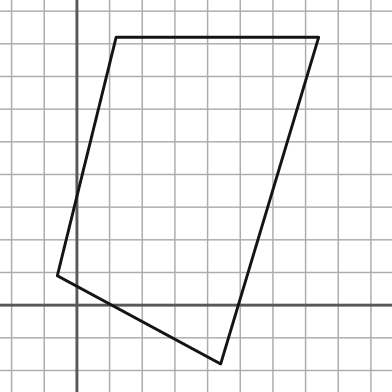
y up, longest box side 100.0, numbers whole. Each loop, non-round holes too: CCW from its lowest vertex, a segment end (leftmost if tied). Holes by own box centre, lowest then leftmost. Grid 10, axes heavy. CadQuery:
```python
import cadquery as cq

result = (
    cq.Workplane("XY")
    .moveTo(44.0, -18.0)
    .lineTo(74.0, 82.0)
    .lineTo(12.0, 82.0)
    .lineTo(-6.0, 9.0)
    .close()
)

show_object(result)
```